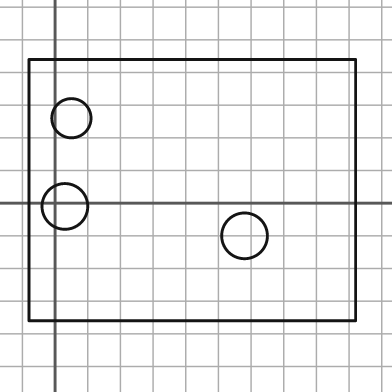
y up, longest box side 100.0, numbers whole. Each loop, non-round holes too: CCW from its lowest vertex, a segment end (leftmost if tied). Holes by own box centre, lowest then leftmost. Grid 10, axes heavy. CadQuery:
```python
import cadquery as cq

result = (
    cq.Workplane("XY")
    .moveTo(-8.0, -36.0)
    .lineTo(92.0, -36.0)
    .lineTo(92.0, 44.0)
    .lineTo(-8.0, 44.0)
    .close()
    .moveTo(58.0, -10.0)
    .circle(7.0)
    .moveTo(3.0, -1.0)
    .circle(7.0)
    .moveTo(5.0, 26.0)
    .circle(6.0)
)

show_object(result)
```